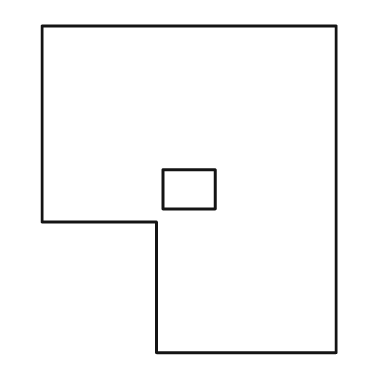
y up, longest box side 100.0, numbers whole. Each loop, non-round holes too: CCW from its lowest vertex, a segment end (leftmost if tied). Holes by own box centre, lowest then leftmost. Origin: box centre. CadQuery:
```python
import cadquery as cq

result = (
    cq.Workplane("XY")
    .moveTo(-10.0, -50.0)
    .lineTo(45.0, -50.0)
    .lineTo(45.0, 50.0)
    .lineTo(-45.0, 50.0)
    .lineTo(-45.0, -10.0)
    .lineTo(-10.0, -10.0)
    .close()
    .moveTo(-8.0, -6.0)
    .lineTo(8.0, -6.0)
    .lineTo(8.0, 6.0)
    .lineTo(-8.0, 6.0)
    .close()
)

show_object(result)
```